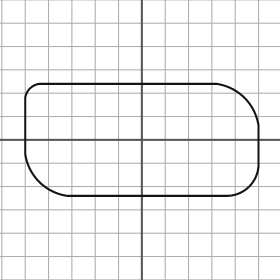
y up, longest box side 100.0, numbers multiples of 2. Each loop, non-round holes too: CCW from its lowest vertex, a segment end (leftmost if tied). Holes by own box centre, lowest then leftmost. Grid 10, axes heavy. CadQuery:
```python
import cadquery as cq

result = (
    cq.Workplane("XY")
    .moveTo(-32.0, -24.0)
    .lineTo(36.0, -24.0)
    .threePointArc((46.0, -20.0), (50.0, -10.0))
    .lineTo(50.0, 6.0)
    .threePointArc((44.0, 18.0), (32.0, 24.0))
    .lineTo(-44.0, 24.0)
    .threePointArc((-48.0, 22.0), (-50.0, 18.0))
    .lineTo(-50.0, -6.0)
    .threePointArc((-44.0, -18.0), (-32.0, -24.0))
    .close()
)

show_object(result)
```